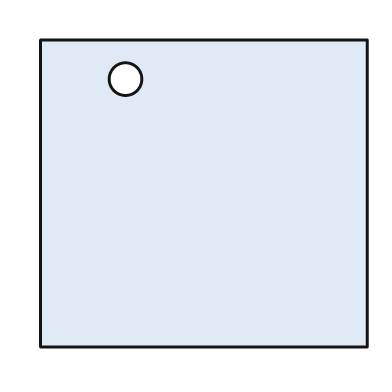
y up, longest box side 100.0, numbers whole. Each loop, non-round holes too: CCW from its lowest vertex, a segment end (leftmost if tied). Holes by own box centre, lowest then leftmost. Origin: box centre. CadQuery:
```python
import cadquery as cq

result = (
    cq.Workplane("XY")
    .moveTo(-50.0, -47.0)
    .lineTo(50.0, -47.0)
    .lineTo(50.0, 47.0)
    .lineTo(-50.0, 47.0)
    .close()
    .moveTo(-24.0, 35.0)
    .circle(5.0)
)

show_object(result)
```